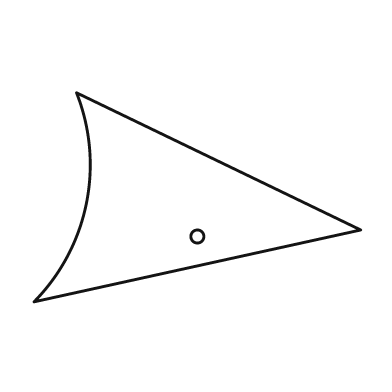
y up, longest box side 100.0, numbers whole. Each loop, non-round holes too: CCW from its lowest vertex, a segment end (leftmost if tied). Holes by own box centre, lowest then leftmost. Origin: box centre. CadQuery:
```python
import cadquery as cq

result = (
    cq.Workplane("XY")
    .moveTo(-50.0, -32.0)
    .lineTo(50.0, -10.0)
    .lineTo(-37.0, 32.0)
    .threePointArc((-34.0, -2.0), (-50.0, -32.0))
    .close()
    .moveTo(0.0, -12.0)
    .circle(2.0)
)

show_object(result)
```